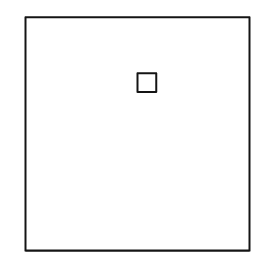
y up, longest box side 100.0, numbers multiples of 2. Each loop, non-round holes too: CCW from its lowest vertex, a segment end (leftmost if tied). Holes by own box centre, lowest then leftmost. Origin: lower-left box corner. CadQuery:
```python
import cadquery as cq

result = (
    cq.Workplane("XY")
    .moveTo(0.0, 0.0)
    .lineTo(96.0, 0.0)
    .lineTo(96.0, 100.0)
    .lineTo(0.0, 100.0)
    .close()
    .moveTo(48.0, 68.0)
    .lineTo(56.0, 68.0)
    .lineTo(56.0, 76.0)
    .lineTo(48.0, 76.0)
    .close()
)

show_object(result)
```